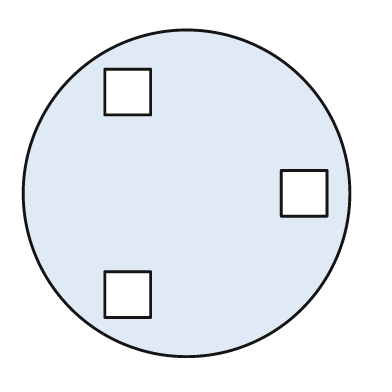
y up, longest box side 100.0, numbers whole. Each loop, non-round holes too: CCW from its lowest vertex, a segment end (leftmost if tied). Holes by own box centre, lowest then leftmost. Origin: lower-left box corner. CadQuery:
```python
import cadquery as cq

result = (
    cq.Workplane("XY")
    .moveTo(50.0, 50.0)
    .circle(50.0)
    .moveTo(25.0, 12.0)
    .lineTo(39.0, 12.0)
    .lineTo(39.0, 26.0)
    .lineTo(25.0, 26.0)
    .close()
    .moveTo(79.0, 43.0)
    .lineTo(93.0, 43.0)
    .lineTo(93.0, 57.0)
    .lineTo(79.0, 57.0)
    .close()
    .moveTo(25.0, 74.0)
    .lineTo(39.0, 74.0)
    .lineTo(39.0, 88.0)
    .lineTo(25.0, 88.0)
    .close()
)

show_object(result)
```